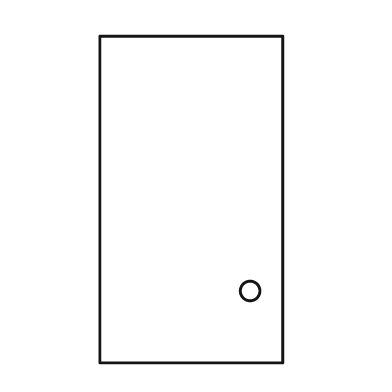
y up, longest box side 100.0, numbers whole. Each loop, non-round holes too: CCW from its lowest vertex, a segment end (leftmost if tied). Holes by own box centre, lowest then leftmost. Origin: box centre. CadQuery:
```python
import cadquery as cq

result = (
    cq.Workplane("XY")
    .moveTo(-28.0, -50.0)
    .lineTo(28.0, -50.0)
    .lineTo(28.0, 50.0)
    .lineTo(-28.0, 50.0)
    .close()
    .moveTo(18.0, -28.0)
    .circle(3.0)
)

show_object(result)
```